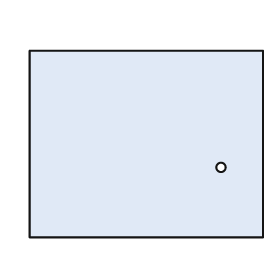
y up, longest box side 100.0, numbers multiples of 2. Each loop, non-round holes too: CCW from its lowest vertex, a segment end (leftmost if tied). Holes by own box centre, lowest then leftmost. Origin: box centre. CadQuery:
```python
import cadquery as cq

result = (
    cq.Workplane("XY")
    .moveTo(-50.0, -40.0)
    .lineTo(50.0, -40.0)
    .lineTo(50.0, 40.0)
    .lineTo(-50.0, 40.0)
    .close()
    .moveTo(32.0, -10.0)
    .circle(2.0)
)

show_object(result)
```